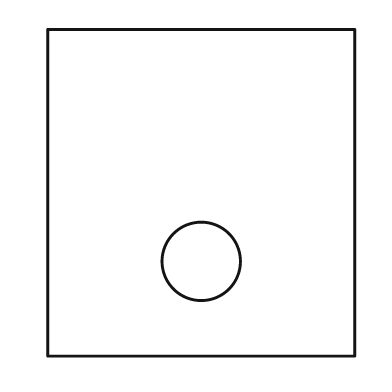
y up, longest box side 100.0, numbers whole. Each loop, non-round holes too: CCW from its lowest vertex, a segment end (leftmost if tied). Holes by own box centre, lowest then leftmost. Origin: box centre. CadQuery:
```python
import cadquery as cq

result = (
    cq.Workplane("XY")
    .moveTo(-47.0, -50.0)
    .lineTo(47.0, -50.0)
    .lineTo(47.0, 50.0)
    .lineTo(-47.0, 50.0)
    .close()
    .moveTo(0.0, -21.0)
    .circle(12.0)
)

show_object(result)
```